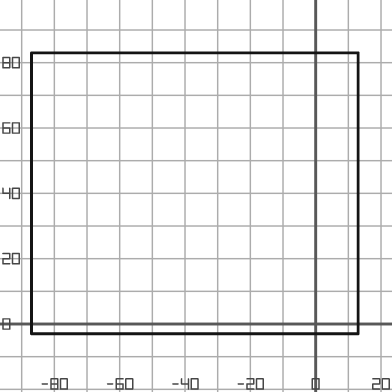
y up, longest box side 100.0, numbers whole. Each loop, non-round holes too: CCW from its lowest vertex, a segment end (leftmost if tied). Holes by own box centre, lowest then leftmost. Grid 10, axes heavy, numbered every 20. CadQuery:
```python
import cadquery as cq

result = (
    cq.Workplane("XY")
    .moveTo(-87.0, -3.0)
    .lineTo(13.0, -3.0)
    .lineTo(13.0, 83.0)
    .lineTo(-87.0, 83.0)
    .close()
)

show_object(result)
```